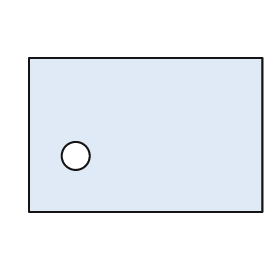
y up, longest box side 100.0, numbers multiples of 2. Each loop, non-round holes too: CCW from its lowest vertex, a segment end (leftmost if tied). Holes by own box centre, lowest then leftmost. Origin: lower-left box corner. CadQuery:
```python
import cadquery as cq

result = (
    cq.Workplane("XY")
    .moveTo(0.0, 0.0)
    .lineTo(100.0, 0.0)
    .lineTo(100.0, 66.0)
    .lineTo(0.0, 66.0)
    .close()
    .moveTo(20.0, 24.0)
    .circle(6.0)
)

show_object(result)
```